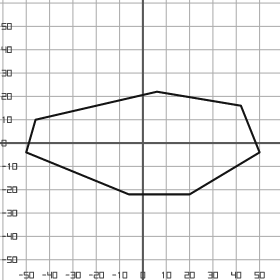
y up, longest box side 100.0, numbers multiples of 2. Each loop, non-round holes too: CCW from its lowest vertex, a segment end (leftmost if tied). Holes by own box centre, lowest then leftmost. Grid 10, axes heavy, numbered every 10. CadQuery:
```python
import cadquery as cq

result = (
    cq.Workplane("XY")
    .moveTo(-6.0, -22.0)
    .lineTo(20.0, -22.0)
    .lineTo(50.0, -4.0)
    .lineTo(42.0, 16.0)
    .lineTo(6.0, 22.0)
    .lineTo(-46.0, 10.0)
    .lineTo(-50.0, -4.0)
    .close()
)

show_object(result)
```